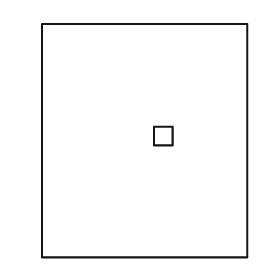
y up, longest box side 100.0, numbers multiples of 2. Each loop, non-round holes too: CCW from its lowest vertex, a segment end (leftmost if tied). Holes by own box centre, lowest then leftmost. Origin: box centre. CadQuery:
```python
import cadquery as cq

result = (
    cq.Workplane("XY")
    .moveTo(-44.0, -50.0)
    .lineTo(44.0, -50.0)
    .lineTo(44.0, 50.0)
    .lineTo(-44.0, 50.0)
    .close()
    .moveTo(4.0, -2.0)
    .lineTo(12.0, -2.0)
    .lineTo(12.0, 6.0)
    .lineTo(4.0, 6.0)
    .close()
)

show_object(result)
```